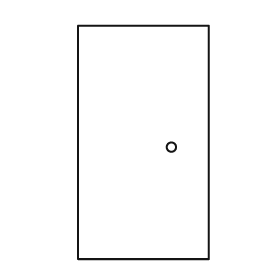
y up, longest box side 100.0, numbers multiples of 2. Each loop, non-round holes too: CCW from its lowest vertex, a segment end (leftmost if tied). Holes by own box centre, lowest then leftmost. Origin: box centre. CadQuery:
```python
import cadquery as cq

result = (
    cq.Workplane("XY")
    .moveTo(-28.0, -50.0)
    .lineTo(28.0, -50.0)
    .lineTo(28.0, 50.0)
    .lineTo(-28.0, 50.0)
    .close()
    .moveTo(12.0, -2.0)
    .circle(2.0)
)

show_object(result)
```